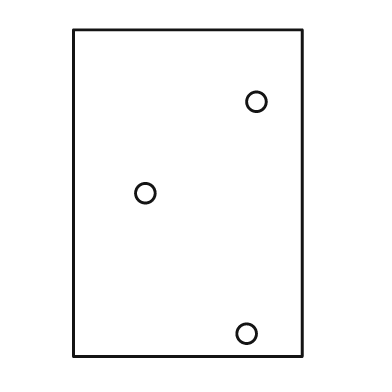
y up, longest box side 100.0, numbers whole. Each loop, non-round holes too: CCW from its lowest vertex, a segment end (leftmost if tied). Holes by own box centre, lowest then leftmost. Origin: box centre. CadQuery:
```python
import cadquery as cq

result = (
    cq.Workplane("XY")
    .moveTo(-35.0, -50.0)
    .lineTo(35.0, -50.0)
    .lineTo(35.0, 50.0)
    .lineTo(-35.0, 50.0)
    .close()
    .moveTo(18.0, -43.0)
    .circle(3.0)
    .moveTo(-13.0, 0.0)
    .circle(3.0)
    .moveTo(21.0, 28.0)
    .circle(3.0)
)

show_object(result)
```